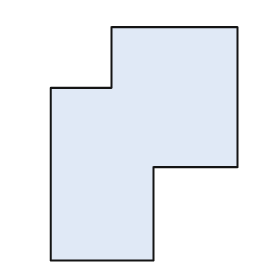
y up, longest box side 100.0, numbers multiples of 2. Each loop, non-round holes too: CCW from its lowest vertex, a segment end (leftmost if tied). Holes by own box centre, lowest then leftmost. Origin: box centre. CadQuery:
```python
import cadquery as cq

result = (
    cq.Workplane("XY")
    .moveTo(-40.0, -50.0)
    .lineTo(4.0, -50.0)
    .lineTo(4.0, -10.0)
    .lineTo(40.0, -10.0)
    .lineTo(40.0, 50.0)
    .lineTo(-14.0, 50.0)
    .lineTo(-14.0, 24.0)
    .lineTo(-40.0, 24.0)
    .close()
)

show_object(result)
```